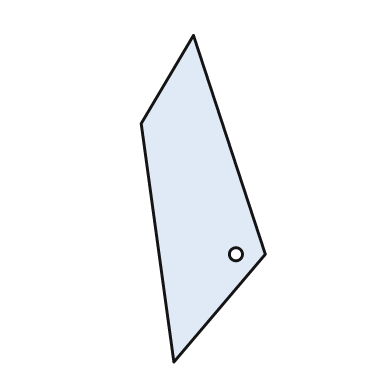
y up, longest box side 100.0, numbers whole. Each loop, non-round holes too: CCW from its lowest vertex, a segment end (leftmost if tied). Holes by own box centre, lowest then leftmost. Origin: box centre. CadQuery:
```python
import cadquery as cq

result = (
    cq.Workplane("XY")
    .moveTo(-9.0, -50.0)
    .lineTo(19.0, -17.0)
    .lineTo(-3.0, 50.0)
    .lineTo(-19.0, 23.0)
    .close()
    .moveTo(10.0, -17.0)
    .circle(2.0)
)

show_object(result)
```